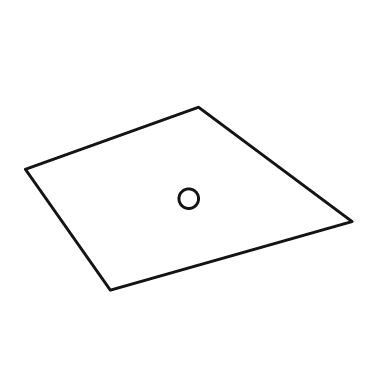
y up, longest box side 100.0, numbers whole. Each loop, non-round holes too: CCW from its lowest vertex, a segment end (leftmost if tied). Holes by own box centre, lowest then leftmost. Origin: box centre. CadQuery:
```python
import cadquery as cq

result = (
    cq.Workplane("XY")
    .moveTo(-24.0, -28.0)
    .lineTo(50.0, -7.0)
    .lineTo(3.0, 28.0)
    .lineTo(-50.0, 9.0)
    .close()
    .moveTo(0.0, 0.0)
    .circle(3.0)
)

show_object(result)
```